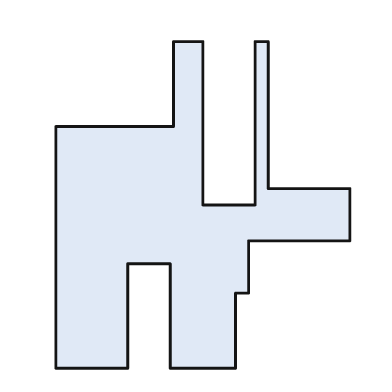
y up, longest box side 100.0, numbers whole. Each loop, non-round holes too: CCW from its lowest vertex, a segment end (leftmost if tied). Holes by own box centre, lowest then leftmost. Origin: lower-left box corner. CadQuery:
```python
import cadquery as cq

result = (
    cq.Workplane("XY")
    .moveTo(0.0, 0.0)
    .lineTo(22.0, 0.0)
    .lineTo(22.0, 32.0)
    .lineTo(35.0, 32.0)
    .lineTo(35.0, 0.0)
    .lineTo(55.0, 0.0)
    .lineTo(55.0, 23.0)
    .lineTo(59.0, 23.0)
    .lineTo(59.0, 39.0)
    .lineTo(90.0, 39.0)
    .lineTo(90.0, 55.0)
    .lineTo(65.0, 55.0)
    .lineTo(65.0, 100.0)
    .lineTo(61.0, 100.0)
    .lineTo(61.0, 50.0)
    .lineTo(45.0, 50.0)
    .lineTo(45.0, 100.0)
    .lineTo(36.0, 100.0)
    .lineTo(36.0, 74.0)
    .lineTo(0.0, 74.0)
    .close()
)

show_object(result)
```